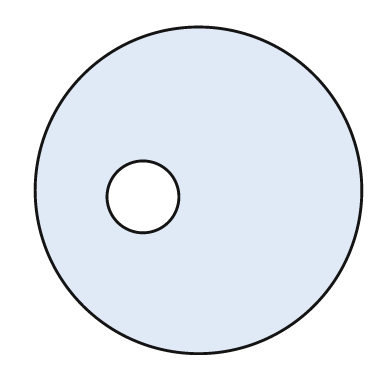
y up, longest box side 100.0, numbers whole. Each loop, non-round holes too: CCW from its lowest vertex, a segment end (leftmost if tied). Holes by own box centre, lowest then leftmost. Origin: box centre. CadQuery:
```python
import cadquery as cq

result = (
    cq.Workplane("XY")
    .moveTo(0.0, 0.0)
    .circle(50.0)
    .moveTo(-17.0, -2.0)
    .circle(11.0)
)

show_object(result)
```